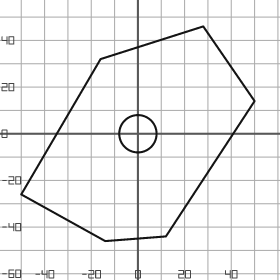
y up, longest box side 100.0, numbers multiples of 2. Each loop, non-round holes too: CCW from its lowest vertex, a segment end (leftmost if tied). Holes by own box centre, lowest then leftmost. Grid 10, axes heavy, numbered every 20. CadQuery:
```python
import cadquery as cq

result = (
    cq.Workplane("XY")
    .moveTo(-14.0, -46.0)
    .lineTo(12.0, -44.0)
    .lineTo(50.0, 14.0)
    .lineTo(28.0, 46.0)
    .lineTo(-16.0, 32.0)
    .lineTo(-50.0, -26.0)
    .close()
    .moveTo(0.0, 0.0)
    .circle(8.0)
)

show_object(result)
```